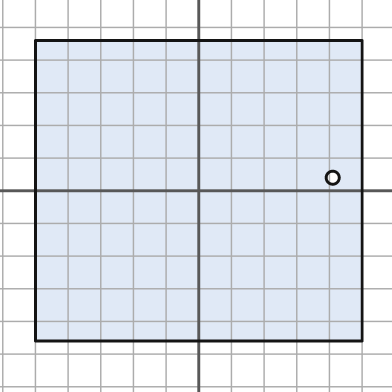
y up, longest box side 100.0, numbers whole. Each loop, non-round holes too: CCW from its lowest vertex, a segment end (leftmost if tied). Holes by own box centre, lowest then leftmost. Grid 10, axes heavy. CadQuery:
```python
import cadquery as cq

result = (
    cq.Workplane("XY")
    .moveTo(-50.0, -46.0)
    .lineTo(50.0, -46.0)
    .lineTo(50.0, 46.0)
    .lineTo(-50.0, 46.0)
    .close()
    .moveTo(41.0, 4.0)
    .circle(2.0)
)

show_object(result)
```